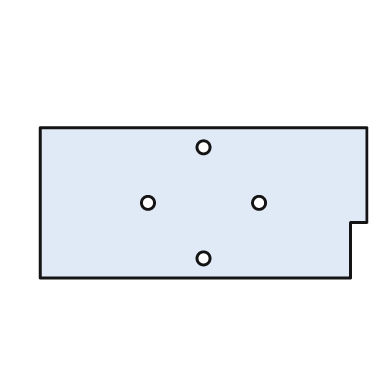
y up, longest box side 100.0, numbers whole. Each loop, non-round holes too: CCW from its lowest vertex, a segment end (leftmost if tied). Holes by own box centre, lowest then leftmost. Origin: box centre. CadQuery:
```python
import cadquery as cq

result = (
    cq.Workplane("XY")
    .moveTo(-50.0, -23.0)
    .lineTo(45.0, -23.0)
    .lineTo(45.0, -6.0)
    .lineTo(50.0, -6.0)
    .lineTo(50.0, 23.0)
    .lineTo(-50.0, 23.0)
    .close()
    .moveTo(0.0, -17.0)
    .circle(2.0)
    .moveTo(-17.0, 0.0)
    .circle(2.0)
    .moveTo(17.0, 0.0)
    .circle(2.0)
    .moveTo(0.0, 17.0)
    .circle(2.0)
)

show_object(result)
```